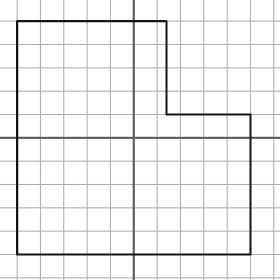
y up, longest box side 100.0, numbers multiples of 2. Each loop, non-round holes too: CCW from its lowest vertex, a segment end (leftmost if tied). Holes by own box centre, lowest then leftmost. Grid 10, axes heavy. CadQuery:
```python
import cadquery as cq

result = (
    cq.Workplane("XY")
    .moveTo(-50.0, -50.0)
    .lineTo(50.0, -50.0)
    .lineTo(50.0, 10.0)
    .lineTo(14.0, 10.0)
    .lineTo(14.0, 50.0)
    .lineTo(-50.0, 50.0)
    .close()
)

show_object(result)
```